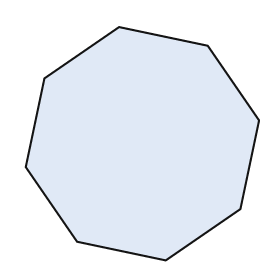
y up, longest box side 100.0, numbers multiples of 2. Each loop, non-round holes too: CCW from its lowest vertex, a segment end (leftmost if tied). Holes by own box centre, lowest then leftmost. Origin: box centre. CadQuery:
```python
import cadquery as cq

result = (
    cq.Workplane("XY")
    .moveTo(10.0, -50.0)
    .lineTo(42.0, -28.0)
    .lineTo(50.0, 10.0)
    .lineTo(28.0, 42.0)
    .lineTo(-10.0, 50.0)
    .lineTo(-42.0, 28.0)
    .lineTo(-50.0, -10.0)
    .lineTo(-28.0, -42.0)
    .close()
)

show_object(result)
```